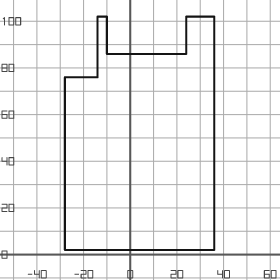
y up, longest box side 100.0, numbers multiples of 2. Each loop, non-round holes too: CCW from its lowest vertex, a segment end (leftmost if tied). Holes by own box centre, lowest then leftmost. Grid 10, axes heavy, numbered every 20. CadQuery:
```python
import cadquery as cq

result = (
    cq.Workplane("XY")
    .moveTo(-28.0, 2.0)
    .lineTo(36.0, 2.0)
    .lineTo(36.0, 102.0)
    .lineTo(24.0, 102.0)
    .lineTo(24.0, 86.0)
    .lineTo(-10.0, 86.0)
    .lineTo(-10.0, 102.0)
    .lineTo(-14.0, 102.0)
    .lineTo(-14.0, 76.0)
    .lineTo(-28.0, 76.0)
    .close()
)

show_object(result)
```